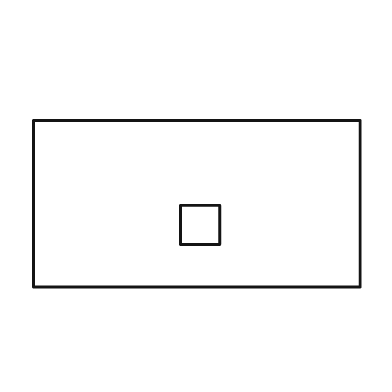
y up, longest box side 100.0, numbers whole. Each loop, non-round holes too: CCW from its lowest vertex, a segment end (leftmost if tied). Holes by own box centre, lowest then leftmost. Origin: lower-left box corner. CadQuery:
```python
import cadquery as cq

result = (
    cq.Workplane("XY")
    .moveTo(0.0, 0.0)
    .lineTo(100.0, 0.0)
    .lineTo(100.0, 51.0)
    .lineTo(0.0, 51.0)
    .close()
    .moveTo(45.0, 13.0)
    .lineTo(57.0, 13.0)
    .lineTo(57.0, 25.0)
    .lineTo(45.0, 25.0)
    .close()
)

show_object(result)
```